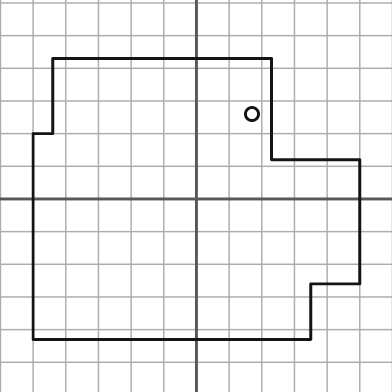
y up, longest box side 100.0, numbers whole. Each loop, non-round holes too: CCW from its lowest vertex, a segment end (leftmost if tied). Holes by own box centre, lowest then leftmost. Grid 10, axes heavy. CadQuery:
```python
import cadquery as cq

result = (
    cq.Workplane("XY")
    .moveTo(-50.0, -43.0)
    .lineTo(35.0, -43.0)
    .lineTo(35.0, -26.0)
    .lineTo(50.0, -26.0)
    .lineTo(50.0, 12.0)
    .lineTo(23.0, 12.0)
    .lineTo(23.0, 43.0)
    .lineTo(-44.0, 43.0)
    .lineTo(-44.0, 20.0)
    .lineTo(-50.0, 20.0)
    .close()
    .moveTo(17.0, 26.0)
    .circle(2.0)
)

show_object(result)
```